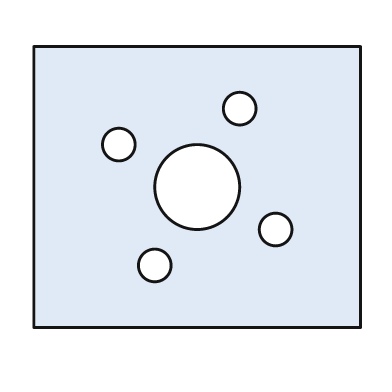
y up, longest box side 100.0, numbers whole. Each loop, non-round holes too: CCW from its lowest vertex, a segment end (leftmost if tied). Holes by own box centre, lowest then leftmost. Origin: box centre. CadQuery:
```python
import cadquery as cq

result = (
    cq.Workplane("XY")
    .moveTo(-50.0, -43.0)
    .lineTo(50.0, -43.0)
    .lineTo(50.0, 43.0)
    .lineTo(-50.0, 43.0)
    .close()
    .moveTo(-13.0, -24.0)
    .circle(5.0)
    .moveTo(24.0, -13.0)
    .circle(5.0)
    .moveTo(0.0, 0.0)
    .circle(13.0)
    .moveTo(-24.0, 13.0)
    .circle(5.0)
    .moveTo(13.0, 24.0)
    .circle(5.0)
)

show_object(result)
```